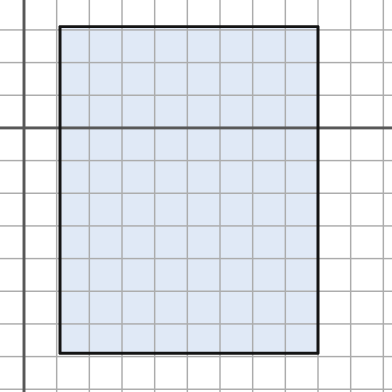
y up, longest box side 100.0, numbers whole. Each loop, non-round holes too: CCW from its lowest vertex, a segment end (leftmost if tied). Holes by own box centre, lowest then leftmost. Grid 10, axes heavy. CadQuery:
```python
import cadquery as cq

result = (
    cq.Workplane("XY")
    .moveTo(11.0, -69.0)
    .lineTo(90.0, -69.0)
    .lineTo(90.0, 31.0)
    .lineTo(11.0, 31.0)
    .close()
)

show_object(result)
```